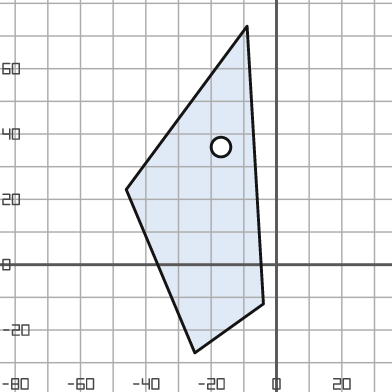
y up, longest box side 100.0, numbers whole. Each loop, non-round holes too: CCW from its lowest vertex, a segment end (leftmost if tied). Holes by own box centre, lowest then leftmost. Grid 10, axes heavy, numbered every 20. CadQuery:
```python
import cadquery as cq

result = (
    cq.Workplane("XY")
    .moveTo(-25.0, -27.0)
    .lineTo(-4.0, -12.0)
    .lineTo(-9.0, 73.0)
    .lineTo(-46.0, 23.0)
    .close()
    .moveTo(-17.0, 36.0)
    .circle(3.0)
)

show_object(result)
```